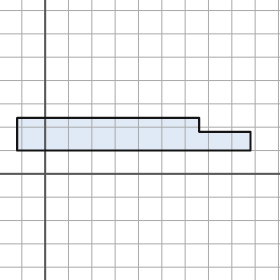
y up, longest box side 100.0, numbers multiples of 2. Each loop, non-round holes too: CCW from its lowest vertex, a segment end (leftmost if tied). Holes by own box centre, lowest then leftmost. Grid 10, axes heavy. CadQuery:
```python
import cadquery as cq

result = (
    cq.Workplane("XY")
    .moveTo(-12.0, 10.0)
    .lineTo(88.0, 10.0)
    .lineTo(88.0, 18.0)
    .lineTo(66.0, 18.0)
    .lineTo(66.0, 24.0)
    .lineTo(-12.0, 24.0)
    .close()
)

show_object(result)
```